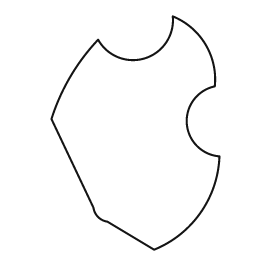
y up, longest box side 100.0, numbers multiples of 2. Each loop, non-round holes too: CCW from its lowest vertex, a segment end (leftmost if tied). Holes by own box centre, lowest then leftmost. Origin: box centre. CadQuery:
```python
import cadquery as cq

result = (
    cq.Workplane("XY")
    .moveTo(8.0, -50.0)
    .threePointArc((28.0, -34.0), (36.0, -10.0))
    .threePointArc((22.0, 4.0), (34.0, 20.0))
    .threePointArc((30.0, 38.0), (16.0, 50.0))
    .threePointArc((4.0, 32.0), (-16.0, 40.0))
    .threePointArc((-28.0, 24.0), (-36.0, 6.0))
    .lineTo(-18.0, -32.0)
    .threePointArc((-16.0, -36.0), (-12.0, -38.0))
    .close()
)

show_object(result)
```